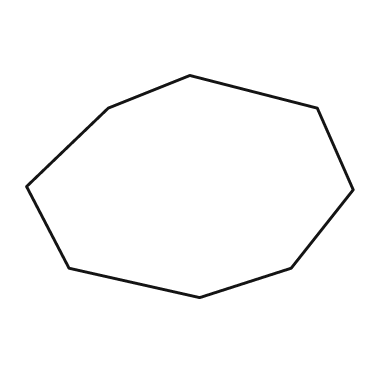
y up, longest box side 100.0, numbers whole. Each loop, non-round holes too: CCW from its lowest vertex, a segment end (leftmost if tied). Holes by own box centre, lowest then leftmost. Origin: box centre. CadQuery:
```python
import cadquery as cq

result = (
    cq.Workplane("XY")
    .moveTo(3.0, -34.0)
    .lineTo(31.0, -25.0)
    .lineTo(50.0, -1.0)
    .lineTo(39.0, 24.0)
    .lineTo(0.0, 34.0)
    .lineTo(-25.0, 24.0)
    .lineTo(-50.0, 0.0)
    .lineTo(-37.0, -25.0)
    .close()
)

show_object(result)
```